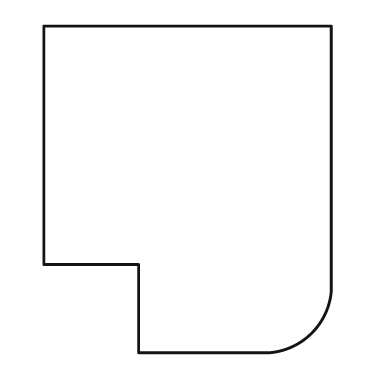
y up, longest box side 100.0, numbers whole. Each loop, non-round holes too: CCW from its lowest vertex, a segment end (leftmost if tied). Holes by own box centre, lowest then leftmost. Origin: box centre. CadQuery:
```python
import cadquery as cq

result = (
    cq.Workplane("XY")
    .moveTo(-15.0, -50.0)
    .lineTo(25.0, -50.0)
    .threePointArc((38.0, -44.0), (44.0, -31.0))
    .lineTo(44.0, 50.0)
    .lineTo(-44.0, 50.0)
    .lineTo(-44.0, -23.0)
    .lineTo(-15.0, -23.0)
    .close()
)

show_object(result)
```